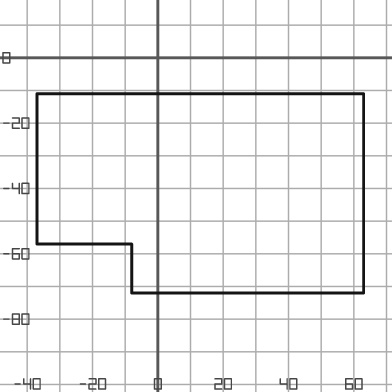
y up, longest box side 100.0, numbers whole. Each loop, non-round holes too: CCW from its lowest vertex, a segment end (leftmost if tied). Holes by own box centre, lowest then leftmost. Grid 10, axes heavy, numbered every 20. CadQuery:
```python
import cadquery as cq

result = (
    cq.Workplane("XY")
    .moveTo(-8.0, -72.0)
    .lineTo(63.0, -72.0)
    .lineTo(63.0, -11.0)
    .lineTo(-37.0, -11.0)
    .lineTo(-37.0, -57.0)
    .lineTo(-8.0, -57.0)
    .close()
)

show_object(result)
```